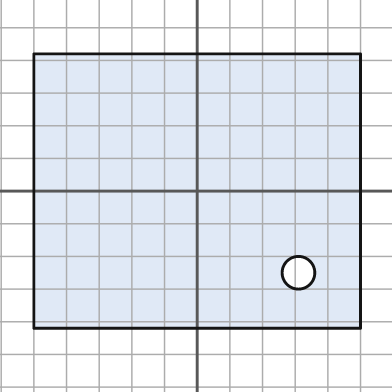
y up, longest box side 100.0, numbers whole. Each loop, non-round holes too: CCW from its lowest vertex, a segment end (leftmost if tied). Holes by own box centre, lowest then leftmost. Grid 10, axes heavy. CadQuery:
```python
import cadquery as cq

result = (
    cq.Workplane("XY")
    .moveTo(-50.0, -42.0)
    .lineTo(50.0, -42.0)
    .lineTo(50.0, 42.0)
    .lineTo(-50.0, 42.0)
    .close()
    .moveTo(31.0, -25.0)
    .circle(5.0)
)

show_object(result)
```